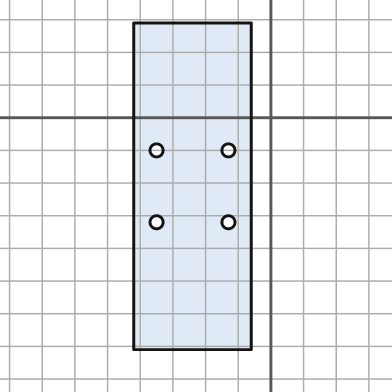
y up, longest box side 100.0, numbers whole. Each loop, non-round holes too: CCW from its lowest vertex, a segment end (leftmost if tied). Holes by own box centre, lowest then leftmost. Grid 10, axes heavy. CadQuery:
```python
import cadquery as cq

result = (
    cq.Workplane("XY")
    .moveTo(-42.0, -71.0)
    .lineTo(-6.0, -71.0)
    .lineTo(-6.0, 29.0)
    .lineTo(-42.0, 29.0)
    .close()
    .moveTo(-35.0, -32.0)
    .circle(2.0)
    .moveTo(-13.0, -32.0)
    .circle(2.0)
    .moveTo(-35.0, -10.0)
    .circle(2.0)
    .moveTo(-13.0, -10.0)
    .circle(2.0)
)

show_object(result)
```